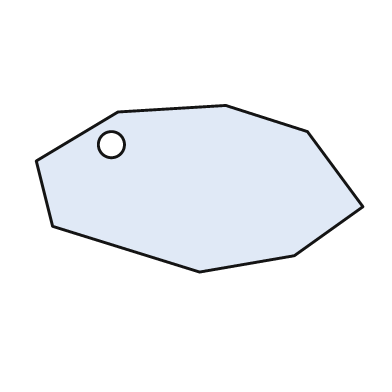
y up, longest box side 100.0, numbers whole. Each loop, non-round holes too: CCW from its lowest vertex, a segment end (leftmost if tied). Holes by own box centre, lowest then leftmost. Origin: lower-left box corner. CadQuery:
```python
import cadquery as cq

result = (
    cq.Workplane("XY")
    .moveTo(50.0, 0.0)
    .lineTo(79.0, 5.0)
    .lineTo(100.0, 20.0)
    .lineTo(83.0, 43.0)
    .lineTo(58.0, 51.0)
    .lineTo(25.0, 49.0)
    .lineTo(0.0, 34.0)
    .lineTo(5.0, 14.0)
    .close()
    .moveTo(23.0, 39.0)
    .circle(4.0)
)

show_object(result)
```